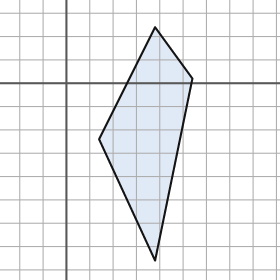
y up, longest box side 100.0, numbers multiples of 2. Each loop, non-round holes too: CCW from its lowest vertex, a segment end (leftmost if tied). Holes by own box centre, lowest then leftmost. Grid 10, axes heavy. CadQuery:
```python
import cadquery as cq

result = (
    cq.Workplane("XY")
    .moveTo(38.0, -76.0)
    .lineTo(54.0, 2.0)
    .lineTo(38.0, 24.0)
    .lineTo(14.0, -24.0)
    .close()
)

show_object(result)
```